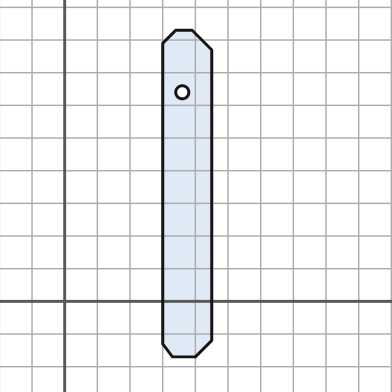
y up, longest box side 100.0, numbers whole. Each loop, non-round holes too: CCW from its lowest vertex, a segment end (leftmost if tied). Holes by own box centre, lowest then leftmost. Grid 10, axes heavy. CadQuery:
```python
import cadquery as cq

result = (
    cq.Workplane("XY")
    .moveTo(33.0, -17.0)
    .lineTo(40.0, -17.0)
    .lineTo(45.0, -12.0)
    .lineTo(45.0, 77.0)
    .lineTo(39.0, 83.0)
    .lineTo(34.0, 83.0)
    .lineTo(30.0, 79.0)
    .lineTo(30.0, -13.0)
    .close()
    .moveTo(36.0, 64.0)
    .circle(2.0)
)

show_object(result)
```